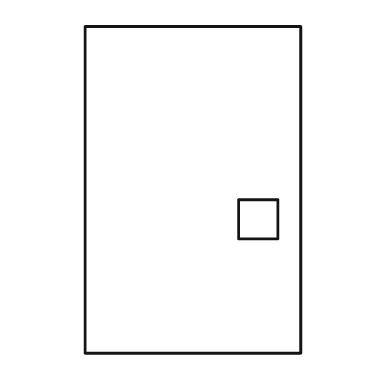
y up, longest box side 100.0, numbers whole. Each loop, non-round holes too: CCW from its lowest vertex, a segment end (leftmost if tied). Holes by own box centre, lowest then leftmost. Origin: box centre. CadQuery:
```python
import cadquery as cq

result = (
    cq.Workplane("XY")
    .moveTo(-33.0, -50.0)
    .lineTo(33.0, -50.0)
    .lineTo(33.0, 50.0)
    .lineTo(-33.0, 50.0)
    .close()
    .moveTo(14.0, -15.0)
    .lineTo(26.0, -15.0)
    .lineTo(26.0, -3.0)
    .lineTo(14.0, -3.0)
    .close()
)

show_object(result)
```